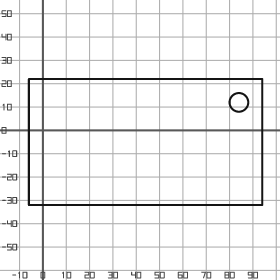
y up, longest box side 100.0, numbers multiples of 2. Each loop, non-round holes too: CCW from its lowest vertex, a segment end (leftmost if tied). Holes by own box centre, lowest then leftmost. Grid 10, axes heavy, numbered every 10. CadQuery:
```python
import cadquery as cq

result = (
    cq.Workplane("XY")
    .moveTo(-6.0, -32.0)
    .lineTo(94.0, -32.0)
    .lineTo(94.0, 22.0)
    .lineTo(-6.0, 22.0)
    .close()
    .moveTo(84.0, 12.0)
    .circle(4.0)
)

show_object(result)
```